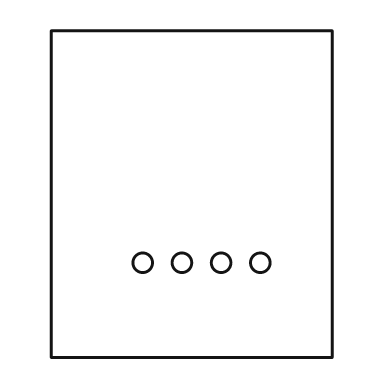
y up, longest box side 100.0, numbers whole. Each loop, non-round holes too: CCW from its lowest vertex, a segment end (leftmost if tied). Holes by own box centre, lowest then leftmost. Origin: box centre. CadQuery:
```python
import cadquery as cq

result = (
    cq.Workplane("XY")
    .moveTo(-43.0, -50.0)
    .lineTo(43.0, -50.0)
    .lineTo(43.0, 50.0)
    .lineTo(-43.0, 50.0)
    .close()
    .moveTo(-15.0, -21.0)
    .circle(3.0)
    .moveTo(-3.0, -21.0)
    .circle(3.0)
    .moveTo(9.0, -21.0)
    .circle(3.0)
    .moveTo(21.0, -21.0)
    .circle(3.0)
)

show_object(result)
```